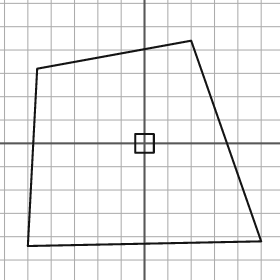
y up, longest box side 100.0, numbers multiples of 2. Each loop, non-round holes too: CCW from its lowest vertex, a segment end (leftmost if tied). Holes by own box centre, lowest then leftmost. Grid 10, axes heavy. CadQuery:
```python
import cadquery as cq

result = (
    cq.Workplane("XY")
    .moveTo(-50.0, -44.0)
    .lineTo(50.0, -42.0)
    .lineTo(20.0, 44.0)
    .lineTo(-46.0, 32.0)
    .close()
    .moveTo(-4.0, -4.0)
    .lineTo(4.0, -4.0)
    .lineTo(4.0, 4.0)
    .lineTo(-4.0, 4.0)
    .close()
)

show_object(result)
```